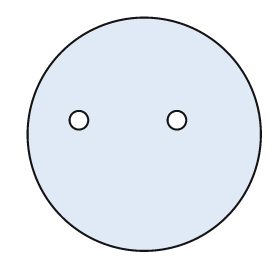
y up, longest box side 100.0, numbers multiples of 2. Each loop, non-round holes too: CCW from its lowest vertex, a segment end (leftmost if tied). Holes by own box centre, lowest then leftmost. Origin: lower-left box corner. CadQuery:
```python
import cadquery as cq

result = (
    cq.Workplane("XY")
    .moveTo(50.0, 50.0)
    .circle(50.0)
    .moveTo(22.0, 56.0)
    .circle(4.0)
    .moveTo(64.0, 56.0)
    .circle(4.0)
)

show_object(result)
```